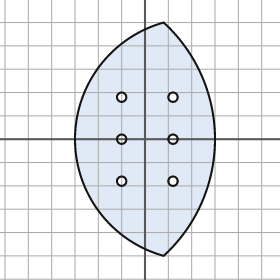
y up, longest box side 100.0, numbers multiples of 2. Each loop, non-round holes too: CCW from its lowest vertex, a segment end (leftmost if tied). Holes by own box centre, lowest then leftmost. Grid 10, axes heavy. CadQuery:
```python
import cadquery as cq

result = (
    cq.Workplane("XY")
    .moveTo(8.0, -50.0)
    .threePointArc((30.0, 0.0), (8.0, 50.0))
    .threePointArc((-30.0, 0.0), (8.0, -50.0))
    .close()
    .moveTo(-10.0, -18.0)
    .circle(2.0)
    .moveTo(12.0, -18.0)
    .circle(2.0)
    .moveTo(-10.0, 0.0)
    .circle(2.0)
    .moveTo(12.0, 0.0)
    .circle(2.0)
    .moveTo(-10.0, 18.0)
    .circle(2.0)
    .moveTo(12.0, 18.0)
    .circle(2.0)
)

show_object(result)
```